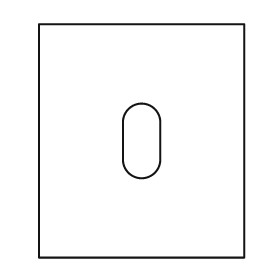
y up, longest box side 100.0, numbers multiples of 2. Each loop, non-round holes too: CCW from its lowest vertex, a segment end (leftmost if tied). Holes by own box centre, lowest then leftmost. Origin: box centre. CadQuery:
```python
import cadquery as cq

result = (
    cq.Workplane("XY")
    .moveTo(-44.0, -50.0)
    .lineTo(44.0, -50.0)
    .lineTo(44.0, 50.0)
    .lineTo(-44.0, 50.0)
    .close()
    .moveTo(-8.0, -8.0)
    .threePointArc((0.0, -16.0), (8.0, -8.0))
    .lineTo(8.0, 8.0)
    .threePointArc((0.0, 16.0), (-8.0, 8.0))
    .close()
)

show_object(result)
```